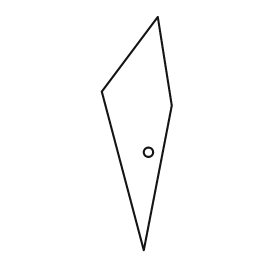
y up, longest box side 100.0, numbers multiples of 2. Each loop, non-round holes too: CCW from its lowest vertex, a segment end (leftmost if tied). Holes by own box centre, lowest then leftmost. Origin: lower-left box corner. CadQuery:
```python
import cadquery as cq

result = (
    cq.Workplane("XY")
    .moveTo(18.0, 0.0)
    .lineTo(30.0, 62.0)
    .lineTo(24.0, 100.0)
    .lineTo(0.0, 68.0)
    .close()
    .moveTo(20.0, 42.0)
    .circle(2.0)
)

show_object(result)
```